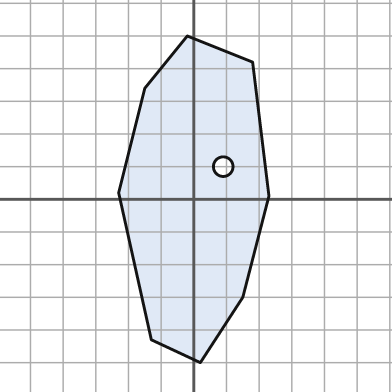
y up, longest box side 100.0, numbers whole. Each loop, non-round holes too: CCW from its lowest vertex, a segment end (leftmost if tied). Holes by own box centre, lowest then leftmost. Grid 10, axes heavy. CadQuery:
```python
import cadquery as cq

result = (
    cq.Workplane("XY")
    .moveTo(2.0, -50.0)
    .lineTo(15.0, -30.0)
    .lineTo(23.0, 1.0)
    .lineTo(18.0, 42.0)
    .lineTo(-2.0, 50.0)
    .lineTo(-15.0, 34.0)
    .lineTo(-23.0, 2.0)
    .lineTo(-13.0, -43.0)
    .close()
    .moveTo(9.0, 10.0)
    .circle(3.0)
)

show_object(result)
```